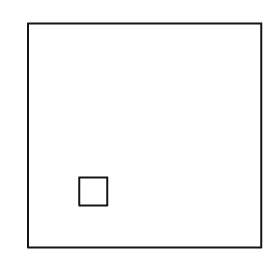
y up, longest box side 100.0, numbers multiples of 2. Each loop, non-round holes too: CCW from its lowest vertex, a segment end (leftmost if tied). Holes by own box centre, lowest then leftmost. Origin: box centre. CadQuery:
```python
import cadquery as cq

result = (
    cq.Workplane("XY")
    .moveTo(-50.0, -48.0)
    .lineTo(50.0, -48.0)
    .lineTo(50.0, 48.0)
    .lineTo(-50.0, 48.0)
    .close()
    .moveTo(-28.0, -30.0)
    .lineTo(-16.0, -30.0)
    .lineTo(-16.0, -18.0)
    .lineTo(-28.0, -18.0)
    .close()
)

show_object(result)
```